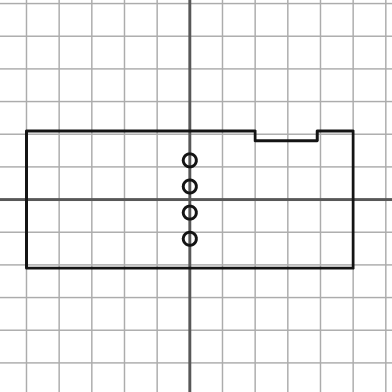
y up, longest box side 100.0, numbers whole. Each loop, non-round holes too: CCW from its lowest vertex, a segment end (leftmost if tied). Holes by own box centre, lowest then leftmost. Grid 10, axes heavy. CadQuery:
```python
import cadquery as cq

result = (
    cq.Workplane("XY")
    .moveTo(-50.0, -21.0)
    .lineTo(50.0, -21.0)
    .lineTo(50.0, 21.0)
    .lineTo(39.0, 21.0)
    .lineTo(39.0, 18.0)
    .lineTo(20.0, 18.0)
    .lineTo(20.0, 21.0)
    .lineTo(-50.0, 21.0)
    .close()
    .moveTo(0.0, -12.0)
    .circle(2.0)
    .moveTo(0.0, -4.0)
    .circle(2.0)
    .moveTo(0.0, 4.0)
    .circle(2.0)
    .moveTo(0.0, 12.0)
    .circle(2.0)
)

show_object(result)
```